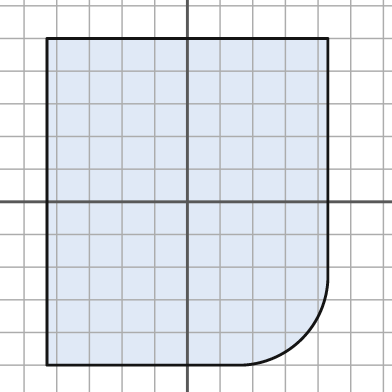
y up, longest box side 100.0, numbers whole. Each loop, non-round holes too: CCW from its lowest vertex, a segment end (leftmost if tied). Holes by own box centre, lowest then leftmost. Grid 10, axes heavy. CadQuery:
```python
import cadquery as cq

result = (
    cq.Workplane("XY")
    .moveTo(-43.0, -50.0)
    .lineTo(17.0, -50.0)
    .threePointArc((35.0, -42.0), (43.0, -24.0))
    .lineTo(43.0, 50.0)
    .lineTo(-43.0, 50.0)
    .close()
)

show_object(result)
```